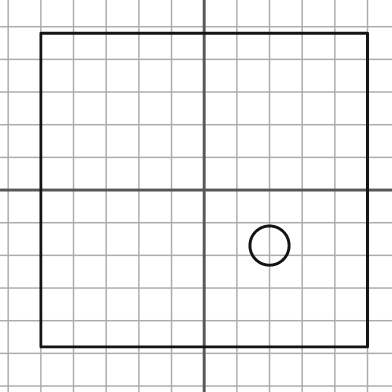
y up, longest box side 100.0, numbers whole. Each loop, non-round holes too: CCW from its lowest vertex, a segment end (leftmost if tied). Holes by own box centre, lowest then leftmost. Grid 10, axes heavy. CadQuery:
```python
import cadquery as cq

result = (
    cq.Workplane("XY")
    .moveTo(-50.0, -48.0)
    .lineTo(50.0, -48.0)
    .lineTo(50.0, 48.0)
    .lineTo(-50.0, 48.0)
    .close()
    .moveTo(20.0, -17.0)
    .circle(6.0)
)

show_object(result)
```